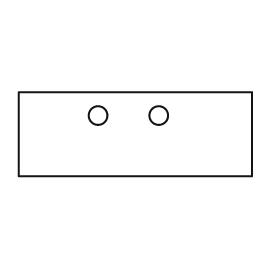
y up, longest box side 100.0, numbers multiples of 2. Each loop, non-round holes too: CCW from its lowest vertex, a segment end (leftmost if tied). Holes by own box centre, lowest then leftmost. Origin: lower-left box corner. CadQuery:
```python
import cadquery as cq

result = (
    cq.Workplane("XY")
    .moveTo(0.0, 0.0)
    .lineTo(100.0, 0.0)
    .lineTo(100.0, 36.0)
    .lineTo(0.0, 36.0)
    .close()
    .moveTo(34.0, 26.0)
    .circle(4.0)
    .moveTo(60.0, 26.0)
    .circle(4.0)
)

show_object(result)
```